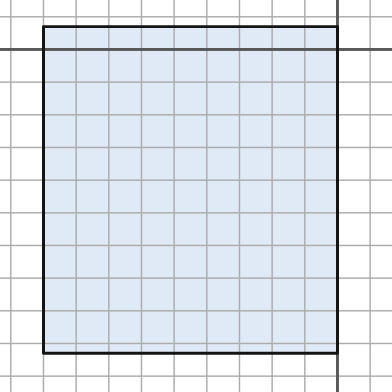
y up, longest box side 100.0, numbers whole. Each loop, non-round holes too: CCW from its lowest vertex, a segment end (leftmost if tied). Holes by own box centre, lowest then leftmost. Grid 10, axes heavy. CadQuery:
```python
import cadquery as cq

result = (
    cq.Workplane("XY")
    .moveTo(-90.0, -93.0)
    .lineTo(0.0, -93.0)
    .lineTo(0.0, 7.0)
    .lineTo(-90.0, 7.0)
    .close()
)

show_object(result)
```